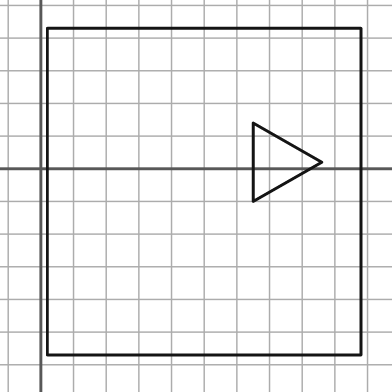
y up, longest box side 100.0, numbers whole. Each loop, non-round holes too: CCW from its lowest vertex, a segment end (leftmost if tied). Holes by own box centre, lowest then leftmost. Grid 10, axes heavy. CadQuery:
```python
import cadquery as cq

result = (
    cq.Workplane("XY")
    .moveTo(2.0, -57.0)
    .lineTo(98.0, -57.0)
    .lineTo(98.0, 43.0)
    .lineTo(2.0, 43.0)
    .close()
    .moveTo(65.0, -10.0)
    .lineTo(86.0, 2.0)
    .lineTo(65.0, 14.0)
    .close()
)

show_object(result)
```